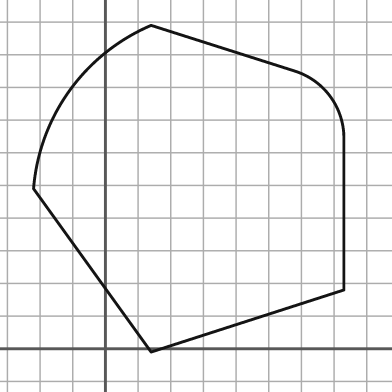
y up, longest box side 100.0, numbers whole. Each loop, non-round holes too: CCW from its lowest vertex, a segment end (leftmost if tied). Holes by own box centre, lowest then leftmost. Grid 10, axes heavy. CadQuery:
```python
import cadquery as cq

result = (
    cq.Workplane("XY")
    .moveTo(14.0, -1.0)
    .lineTo(73.0, 18.0)
    .lineTo(73.0, 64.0)
    .threePointArc((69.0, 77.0), (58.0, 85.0))
    .lineTo(14.0, 99.0)
    .threePointArc((-11.0, 79.0), (-22.0, 49.0))
    .close()
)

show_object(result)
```